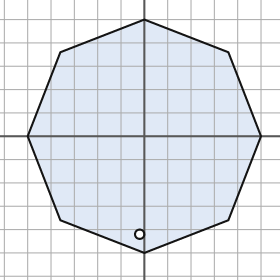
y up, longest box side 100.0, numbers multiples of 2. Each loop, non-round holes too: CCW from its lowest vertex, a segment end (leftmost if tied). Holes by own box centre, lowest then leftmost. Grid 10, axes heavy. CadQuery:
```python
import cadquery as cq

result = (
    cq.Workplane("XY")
    .moveTo(0.0, -50.0)
    .lineTo(36.0, -36.0)
    .lineTo(50.0, 0.0)
    .lineTo(36.0, 36.0)
    .lineTo(0.0, 50.0)
    .lineTo(-36.0, 36.0)
    .lineTo(-50.0, 0.0)
    .lineTo(-36.0, -36.0)
    .close()
    .moveTo(-2.0, -42.0)
    .circle(2.0)
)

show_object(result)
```